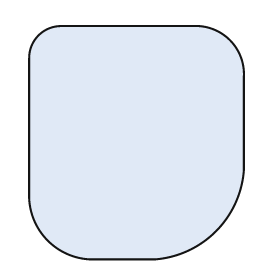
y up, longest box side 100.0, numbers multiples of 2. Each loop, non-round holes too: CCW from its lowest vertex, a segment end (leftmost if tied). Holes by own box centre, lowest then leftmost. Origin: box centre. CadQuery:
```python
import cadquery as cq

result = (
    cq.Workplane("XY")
    .moveTo(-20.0, -50.0)
    .lineTo(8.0, -50.0)
    .threePointArc((34.0, -38.0), (46.0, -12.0))
    .lineTo(46.0, 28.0)
    .threePointArc((40.0, 44.0), (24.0, 50.0))
    .lineTo(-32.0, 50.0)
    .threePointArc((-42.0, 46.0), (-46.0, 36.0))
    .lineTo(-46.0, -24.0)
    .threePointArc((-38.0, -42.0), (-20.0, -50.0))
    .close()
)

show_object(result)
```